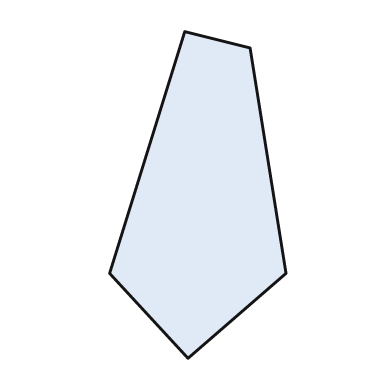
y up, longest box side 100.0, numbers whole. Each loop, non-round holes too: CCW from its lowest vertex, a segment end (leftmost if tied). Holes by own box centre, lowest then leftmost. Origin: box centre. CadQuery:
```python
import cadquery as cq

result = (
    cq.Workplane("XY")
    .moveTo(-3.0, -50.0)
    .lineTo(27.0, -24.0)
    .lineTo(16.0, 45.0)
    .lineTo(-4.0, 50.0)
    .lineTo(-27.0, -24.0)
    .close()
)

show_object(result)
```